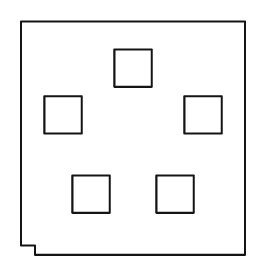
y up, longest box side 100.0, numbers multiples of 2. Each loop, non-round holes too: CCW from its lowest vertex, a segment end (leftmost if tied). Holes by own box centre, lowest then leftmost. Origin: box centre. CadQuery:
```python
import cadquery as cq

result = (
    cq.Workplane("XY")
    .moveTo(-42.0, -50.0)
    .lineTo(48.0, -50.0)
    .lineTo(48.0, 50.0)
    .lineTo(-48.0, 50.0)
    .lineTo(-48.0, -46.0)
    .lineTo(-42.0, -46.0)
    .close()
    .moveTo(-26.0, -32.0)
    .lineTo(-10.0, -32.0)
    .lineTo(-10.0, -16.0)
    .lineTo(-26.0, -16.0)
    .close()
    .moveTo(10.0, -32.0)
    .lineTo(26.0, -32.0)
    .lineTo(26.0, -16.0)
    .lineTo(10.0, -16.0)
    .close()
    .moveTo(-38.0, 2.0)
    .lineTo(-22.0, 2.0)
    .lineTo(-22.0, 18.0)
    .lineTo(-38.0, 18.0)
    .close()
    .moveTo(22.0, 2.0)
    .lineTo(38.0, 2.0)
    .lineTo(38.0, 18.0)
    .lineTo(22.0, 18.0)
    .close()
    .moveTo(-8.0, 22.0)
    .lineTo(8.0, 22.0)
    .lineTo(8.0, 38.0)
    .lineTo(-8.0, 38.0)
    .close()
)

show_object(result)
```